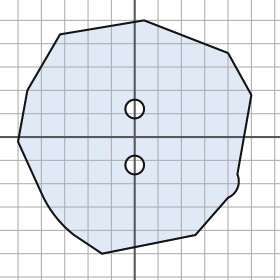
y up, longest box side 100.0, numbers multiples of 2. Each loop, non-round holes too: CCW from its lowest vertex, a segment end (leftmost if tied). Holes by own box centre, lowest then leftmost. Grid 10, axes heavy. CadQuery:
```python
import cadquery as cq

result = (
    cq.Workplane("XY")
    .moveTo(-14.0, -50.0)
    .lineTo(26.0, -42.0)
    .lineTo(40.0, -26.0)
    .threePointArc((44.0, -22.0), (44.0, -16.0))
    .lineTo(50.0, 18.0)
    .lineTo(40.0, 36.0)
    .lineTo(4.0, 50.0)
    .lineTo(-32.0, 44.0)
    .lineTo(-46.0, 20.0)
    .lineTo(-50.0, -2.0)
    .lineTo(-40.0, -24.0)
    .threePointArc((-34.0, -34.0), (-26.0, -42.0))
    .close()
    .moveTo(0.0, -12.0)
    .circle(4.0)
    .moveTo(0.0, 12.0)
    .circle(4.0)
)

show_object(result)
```